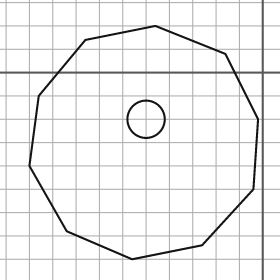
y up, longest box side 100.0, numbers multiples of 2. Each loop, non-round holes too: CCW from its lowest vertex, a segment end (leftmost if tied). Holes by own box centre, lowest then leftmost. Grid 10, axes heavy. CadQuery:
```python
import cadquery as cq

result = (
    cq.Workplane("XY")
    .moveTo(-56.0, -80.0)
    .lineTo(-26.0, -74.0)
    .lineTo(-4.0, -50.0)
    .lineTo(-2.0, -20.0)
    .lineTo(-16.0, 8.0)
    .lineTo(-46.0, 20.0)
    .lineTo(-76.0, 14.0)
    .lineTo(-96.0, -10.0)
    .lineTo(-100.0, -40.0)
    .lineTo(-84.0, -68.0)
    .close()
    .moveTo(-50.0, -20.0)
    .circle(8.0)
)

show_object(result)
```